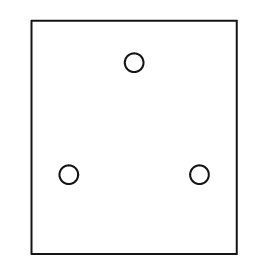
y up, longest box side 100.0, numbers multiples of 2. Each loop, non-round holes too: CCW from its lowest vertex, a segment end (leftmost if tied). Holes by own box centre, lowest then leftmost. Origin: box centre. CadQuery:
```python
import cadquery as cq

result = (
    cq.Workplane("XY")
    .moveTo(-44.0, -50.0)
    .lineTo(44.0, -50.0)
    .lineTo(44.0, 50.0)
    .lineTo(-44.0, 50.0)
    .close()
    .moveTo(-28.0, -16.0)
    .circle(4.0)
    .moveTo(28.0, -16.0)
    .circle(4.0)
    .moveTo(0.0, 32.0)
    .circle(4.0)
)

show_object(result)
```